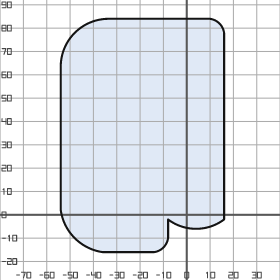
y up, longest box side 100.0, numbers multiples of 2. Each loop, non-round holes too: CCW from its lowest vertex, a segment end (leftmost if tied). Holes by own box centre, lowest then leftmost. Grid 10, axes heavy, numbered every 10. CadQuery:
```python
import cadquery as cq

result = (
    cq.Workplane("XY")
    .moveTo(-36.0, -16.0)
    .lineTo(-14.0, -16.0)
    .threePointArc((-10.0, -14.0), (-8.0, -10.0))
    .lineTo(-8.0, -2.0)
    .threePointArc((4.0, -6.0), (16.0, -2.0))
    .lineTo(16.0, 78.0)
    .threePointArc((14.0, 82.0), (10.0, 84.0))
    .lineTo(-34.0, 84.0)
    .threePointArc((-48.0, 78.0), (-54.0, 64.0))
    .lineTo(-54.0, 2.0)
    .threePointArc((-48.0, -10.0), (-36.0, -16.0))
    .close()
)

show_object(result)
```